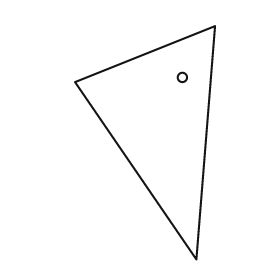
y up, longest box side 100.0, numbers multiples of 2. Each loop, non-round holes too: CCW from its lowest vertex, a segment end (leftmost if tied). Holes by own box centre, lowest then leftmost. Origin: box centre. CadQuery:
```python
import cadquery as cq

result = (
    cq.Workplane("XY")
    .moveTo(22.0, -50.0)
    .lineTo(30.0, 50.0)
    .lineTo(-30.0, 26.0)
    .close()
    .moveTo(16.0, 28.0)
    .circle(2.0)
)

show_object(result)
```